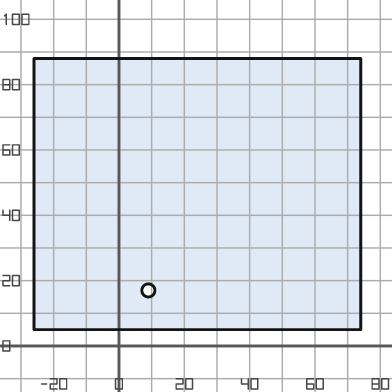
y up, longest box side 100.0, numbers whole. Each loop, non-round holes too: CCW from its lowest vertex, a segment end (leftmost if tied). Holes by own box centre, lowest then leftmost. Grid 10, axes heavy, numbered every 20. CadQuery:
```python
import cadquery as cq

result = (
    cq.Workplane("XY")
    .moveTo(-26.0, 5.0)
    .lineTo(74.0, 5.0)
    .lineTo(74.0, 88.0)
    .lineTo(-26.0, 88.0)
    .close()
    .moveTo(9.0, 17.0)
    .circle(2.0)
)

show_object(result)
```